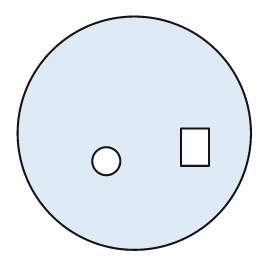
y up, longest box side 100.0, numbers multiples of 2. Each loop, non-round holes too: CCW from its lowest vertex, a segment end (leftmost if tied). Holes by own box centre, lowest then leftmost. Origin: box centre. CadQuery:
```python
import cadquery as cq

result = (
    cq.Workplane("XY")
    .moveTo(0.0, 0.0)
    .circle(50.0)
    .moveTo(-12.0, -12.0)
    .circle(6.0)
    .moveTo(20.0, -14.0)
    .lineTo(32.0, -14.0)
    .lineTo(32.0, 2.0)
    .lineTo(20.0, 2.0)
    .close()
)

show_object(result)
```